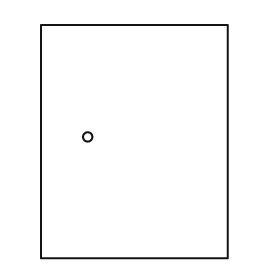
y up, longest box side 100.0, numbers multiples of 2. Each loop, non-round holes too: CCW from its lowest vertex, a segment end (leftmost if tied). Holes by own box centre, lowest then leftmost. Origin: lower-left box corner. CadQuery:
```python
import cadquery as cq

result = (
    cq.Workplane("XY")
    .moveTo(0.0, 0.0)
    .lineTo(80.0, 0.0)
    .lineTo(80.0, 100.0)
    .lineTo(0.0, 100.0)
    .close()
    .moveTo(20.0, 52.0)
    .circle(2.0)
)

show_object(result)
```